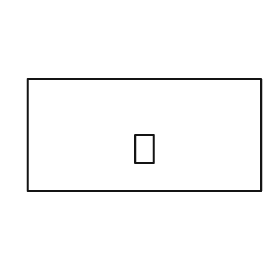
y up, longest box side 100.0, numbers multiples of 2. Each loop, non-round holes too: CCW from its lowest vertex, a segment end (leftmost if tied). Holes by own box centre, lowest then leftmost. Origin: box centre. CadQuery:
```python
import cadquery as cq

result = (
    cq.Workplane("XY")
    .moveTo(-50.0, -24.0)
    .lineTo(50.0, -24.0)
    .lineTo(50.0, 24.0)
    .lineTo(-50.0, 24.0)
    .close()
    .moveTo(-4.0, -12.0)
    .lineTo(4.0, -12.0)
    .lineTo(4.0, 0.0)
    .lineTo(-4.0, 0.0)
    .close()
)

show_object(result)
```